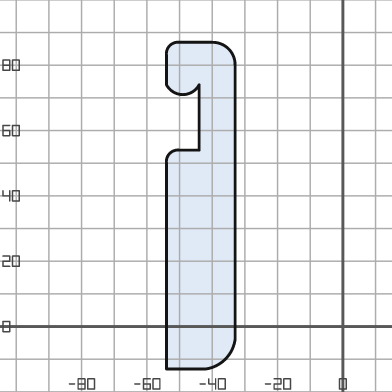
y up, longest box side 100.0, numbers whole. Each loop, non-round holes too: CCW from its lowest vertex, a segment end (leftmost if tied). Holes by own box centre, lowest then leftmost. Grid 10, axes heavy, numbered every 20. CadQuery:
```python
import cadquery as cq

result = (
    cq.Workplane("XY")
    .moveTo(-54.0, -13.0)
    .lineTo(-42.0, -13.0)
    .threePointArc((-36.0, -10.0), (-33.0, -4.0))
    .lineTo(-33.0, 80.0)
    .threePointArc((-35.0, 85.0), (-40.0, 87.0))
    .lineTo(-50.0, 87.0)
    .threePointArc((-53.0, 86.0), (-54.0, 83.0))
    .lineTo(-54.0, 74.0)
    .threePointArc((-49.0, 71.0), (-44.0, 74.0))
    .lineTo(-44.0, 54.0)
    .lineTo(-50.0, 54.0)
    .threePointArc((-53.0, 53.0), (-54.0, 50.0))
    .close()
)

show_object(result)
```